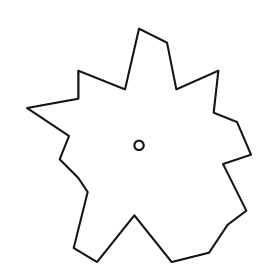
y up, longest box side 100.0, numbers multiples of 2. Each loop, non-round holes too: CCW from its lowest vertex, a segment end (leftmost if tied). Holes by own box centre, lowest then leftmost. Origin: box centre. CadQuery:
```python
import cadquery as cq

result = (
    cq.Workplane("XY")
    .moveTo(-18.0, -50.0)
    .lineTo(-2.0, -30.0)
    .lineTo(14.0, -50.0)
    .lineTo(30.0, -46.0)
    .lineTo(38.0, -34.0)
    .lineTo(46.0, -28.0)
    .lineTo(36.0, -8.0)
    .lineTo(48.0, -4.0)
    .lineTo(42.0, 10.0)
    .lineTo(32.0, 14.0)
    .lineTo(34.0, 32.0)
    .lineTo(16.0, 24.0)
    .lineTo(12.0, 44.0)
    .lineTo(0.0, 50.0)
    .lineTo(-6.0, 24.0)
    .lineTo(-26.0, 32.0)
    .lineTo(-26.0, 20.0)
    .lineTo(-48.0, 16.0)
    .lineTo(-30.0, 4.0)
    .lineTo(-34.0, -6.0)
    .lineTo(-26.0, -14.0)
    .lineTo(-22.0, -20.0)
    .lineTo(-28.0, -44.0)
    .close()
    .moveTo(0.0, 0.0)
    .circle(2.0)
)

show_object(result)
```